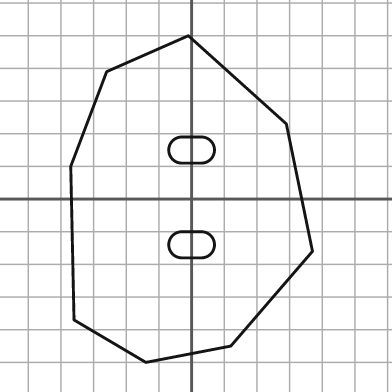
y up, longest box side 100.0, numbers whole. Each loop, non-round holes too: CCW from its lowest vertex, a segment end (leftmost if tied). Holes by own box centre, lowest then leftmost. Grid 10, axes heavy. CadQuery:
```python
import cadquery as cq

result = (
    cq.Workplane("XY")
    .moveTo(-14.0, -50.0)
    .lineTo(12.0, -45.0)
    .lineTo(37.0, -16.0)
    .lineTo(29.0, 23.0)
    .lineTo(-1.0, 50.0)
    .lineTo(-26.0, 39.0)
    .lineTo(-37.0, 10.0)
    .lineTo(-36.0, -37.0)
    .close()
    .moveTo(-3.0, -18.0)
    .lineTo(3.0, -18.0)
    .threePointArc((7.0, -14.0), (3.0, -10.0))
    .lineTo(-3.0, -10.0)
    .threePointArc((-7.0, -14.0), (-3.0, -18.0))
    .close()
    .moveTo(-3.0, 11.0)
    .lineTo(3.0, 11.0)
    .threePointArc((7.0, 15.0), (3.0, 19.0))
    .lineTo(-3.0, 19.0)
    .threePointArc((-7.0, 15.0), (-3.0, 11.0))
    .close()
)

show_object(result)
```